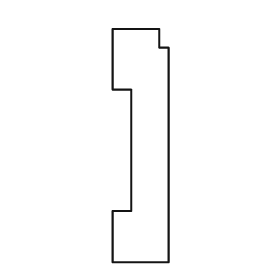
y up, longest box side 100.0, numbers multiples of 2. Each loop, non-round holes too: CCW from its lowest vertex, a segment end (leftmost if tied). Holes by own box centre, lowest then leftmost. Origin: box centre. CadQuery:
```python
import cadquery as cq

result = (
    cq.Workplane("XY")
    .moveTo(-12.0, -50.0)
    .lineTo(12.0, -50.0)
    .lineTo(12.0, 42.0)
    .lineTo(8.0, 42.0)
    .lineTo(8.0, 50.0)
    .lineTo(-12.0, 50.0)
    .lineTo(-12.0, 24.0)
    .lineTo(-4.0, 24.0)
    .lineTo(-4.0, -28.0)
    .lineTo(-12.0, -28.0)
    .close()
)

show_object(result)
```